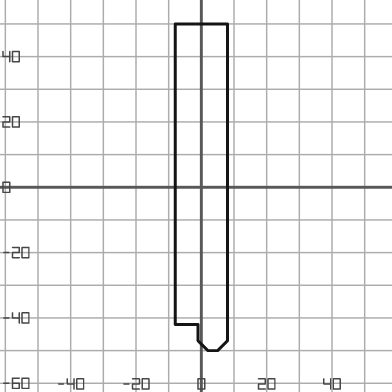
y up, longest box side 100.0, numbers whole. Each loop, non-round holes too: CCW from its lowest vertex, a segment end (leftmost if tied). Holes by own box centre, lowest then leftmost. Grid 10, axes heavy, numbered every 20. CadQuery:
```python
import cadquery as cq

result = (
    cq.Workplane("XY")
    .moveTo(2.0, -50.0)
    .lineTo(5.0, -50.0)
    .lineTo(8.0, -47.0)
    .lineTo(8.0, 50.0)
    .lineTo(-8.0, 50.0)
    .lineTo(-8.0, -42.0)
    .lineTo(-1.0, -42.0)
    .lineTo(-1.0, -47.0)
    .close()
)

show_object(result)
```